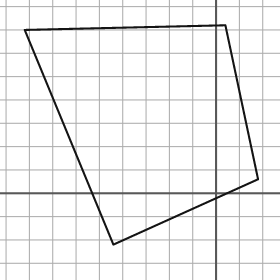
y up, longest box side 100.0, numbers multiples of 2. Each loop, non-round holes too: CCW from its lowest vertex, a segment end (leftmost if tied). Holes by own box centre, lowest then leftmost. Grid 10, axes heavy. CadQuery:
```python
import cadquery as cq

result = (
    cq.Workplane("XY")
    .moveTo(-44.0, -22.0)
    .lineTo(18.0, 6.0)
    .lineTo(4.0, 72.0)
    .lineTo(-82.0, 70.0)
    .close()
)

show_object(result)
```